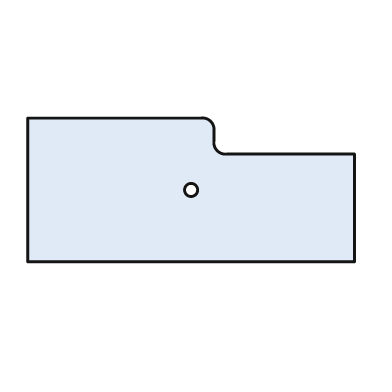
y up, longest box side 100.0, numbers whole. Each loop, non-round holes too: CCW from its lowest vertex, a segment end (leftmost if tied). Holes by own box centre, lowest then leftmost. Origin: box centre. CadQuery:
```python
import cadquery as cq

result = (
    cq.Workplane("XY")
    .moveTo(-50.0, -22.0)
    .lineTo(50.0, -22.0)
    .lineTo(50.0, 11.0)
    .lineTo(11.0, 11.0)
    .threePointArc((8.0, 12.0), (7.0, 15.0))
    .lineTo(7.0, 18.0)
    .threePointArc((6.0, 21.0), (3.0, 22.0))
    .lineTo(-50.0, 22.0)
    .close()
    .moveTo(0.0, 0.0)
    .circle(2.0)
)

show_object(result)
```